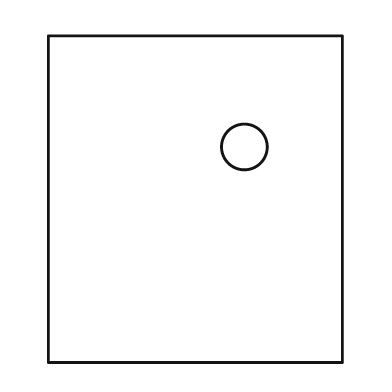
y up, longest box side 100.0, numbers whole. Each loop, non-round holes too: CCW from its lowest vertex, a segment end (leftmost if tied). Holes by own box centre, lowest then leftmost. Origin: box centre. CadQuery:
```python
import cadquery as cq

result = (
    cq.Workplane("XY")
    .moveTo(-45.0, -50.0)
    .lineTo(45.0, -50.0)
    .lineTo(45.0, 50.0)
    .lineTo(-45.0, 50.0)
    .close()
    .moveTo(15.0, 16.0)
    .circle(7.0)
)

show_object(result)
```